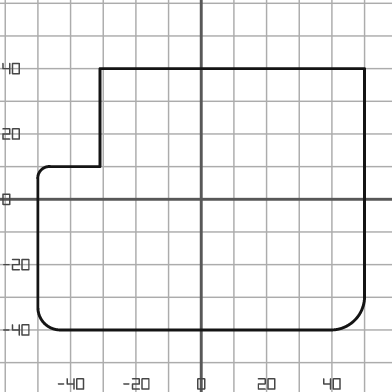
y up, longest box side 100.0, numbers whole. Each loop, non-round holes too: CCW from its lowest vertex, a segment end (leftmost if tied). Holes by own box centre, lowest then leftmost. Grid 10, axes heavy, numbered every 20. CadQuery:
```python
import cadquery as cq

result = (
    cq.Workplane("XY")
    .moveTo(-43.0, -40.0)
    .lineTo(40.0, -40.0)
    .threePointArc((47.0, -37.0), (50.0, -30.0))
    .lineTo(50.0, 40.0)
    .lineTo(-31.0, 40.0)
    .lineTo(-31.0, 10.0)
    .lineTo(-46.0, 10.0)
    .threePointArc((-49.0, 9.0), (-50.0, 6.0))
    .lineTo(-50.0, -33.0)
    .threePointArc((-48.0, -38.0), (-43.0, -40.0))
    .close()
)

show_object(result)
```